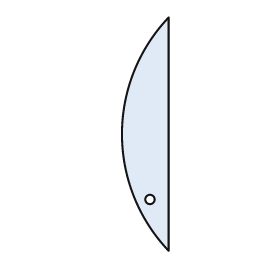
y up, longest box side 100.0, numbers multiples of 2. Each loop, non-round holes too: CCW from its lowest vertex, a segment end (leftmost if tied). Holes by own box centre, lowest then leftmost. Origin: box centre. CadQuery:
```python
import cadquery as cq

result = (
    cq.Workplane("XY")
    .moveTo(10.0, -50.0)
    .lineTo(10.0, 50.0)
    .threePointArc((-10.0, 0.0), (10.0, -50.0))
    .close()
    .moveTo(2.0, -28.0)
    .circle(2.0)
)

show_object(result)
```